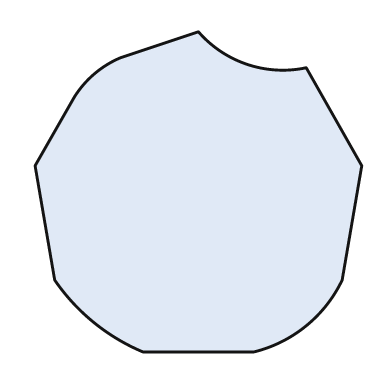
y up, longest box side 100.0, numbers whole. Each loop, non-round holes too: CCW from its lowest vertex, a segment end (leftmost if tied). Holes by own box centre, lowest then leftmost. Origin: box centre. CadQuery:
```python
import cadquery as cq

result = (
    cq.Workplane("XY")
    .moveTo(-17.0, -49.0)
    .lineTo(17.0, -49.0)
    .threePointArc((33.0, -41.0), (44.0, -27.0))
    .lineTo(50.0, 8.0)
    .lineTo(33.0, 38.0)
    .threePointArc((15.0, 39.0), (0.0, 49.0))
    .lineTo(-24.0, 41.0)
    .threePointArc((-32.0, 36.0), (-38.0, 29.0))
    .lineTo(-50.0, 8.0)
    .lineTo(-44.0, -27.0)
    .threePointArc((-32.0, -40.0), (-17.0, -49.0))
    .close()
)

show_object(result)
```